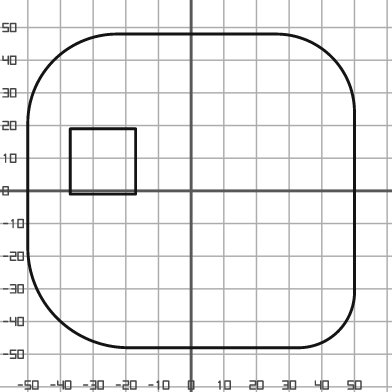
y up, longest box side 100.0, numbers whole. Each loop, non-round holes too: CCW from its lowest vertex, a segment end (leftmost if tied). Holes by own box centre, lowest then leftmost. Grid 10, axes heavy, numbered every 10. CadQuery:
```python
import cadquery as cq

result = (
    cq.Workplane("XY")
    .moveTo(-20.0, -48.0)
    .lineTo(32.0, -48.0)
    .threePointArc((45.0, -43.0), (50.0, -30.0))
    .lineTo(50.0, 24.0)
    .threePointArc((43.0, 41.0), (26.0, 48.0))
    .lineTo(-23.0, 48.0)
    .threePointArc((-42.0, 40.0), (-50.0, 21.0))
    .lineTo(-50.0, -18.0)
    .threePointArc((-41.0, -39.0), (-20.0, -48.0))
    .close()
    .moveTo(-37.0, -1.0)
    .lineTo(-17.0, -1.0)
    .lineTo(-17.0, 19.0)
    .lineTo(-37.0, 19.0)
    .close()
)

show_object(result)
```